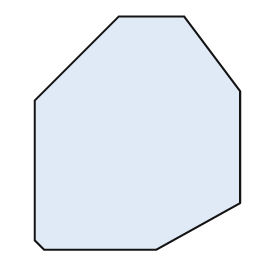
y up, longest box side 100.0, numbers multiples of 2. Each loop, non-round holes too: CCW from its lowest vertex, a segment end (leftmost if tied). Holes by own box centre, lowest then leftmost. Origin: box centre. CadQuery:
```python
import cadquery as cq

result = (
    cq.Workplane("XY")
    .moveTo(-40.0, -50.0)
    .lineTo(8.0, -50.0)
    .lineTo(44.0, -30.0)
    .lineTo(44.0, 18.0)
    .lineTo(20.0, 50.0)
    .lineTo(-8.0, 50.0)
    .lineTo(-44.0, 14.0)
    .lineTo(-44.0, -46.0)
    .close()
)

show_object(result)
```